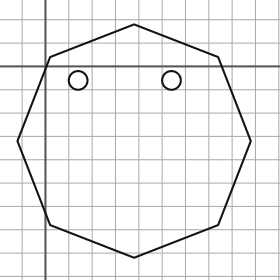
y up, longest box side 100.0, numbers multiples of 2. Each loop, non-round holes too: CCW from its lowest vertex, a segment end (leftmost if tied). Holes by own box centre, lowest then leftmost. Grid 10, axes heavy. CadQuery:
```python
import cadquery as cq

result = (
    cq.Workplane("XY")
    .moveTo(38.0, -82.0)
    .lineTo(74.0, -68.0)
    .lineTo(88.0, -32.0)
    .lineTo(74.0, 4.0)
    .lineTo(38.0, 18.0)
    .lineTo(2.0, 4.0)
    .lineTo(-12.0, -32.0)
    .lineTo(2.0, -68.0)
    .close()
    .moveTo(14.0, -6.0)
    .circle(4.0)
    .moveTo(54.0, -6.0)
    .circle(4.0)
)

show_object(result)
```